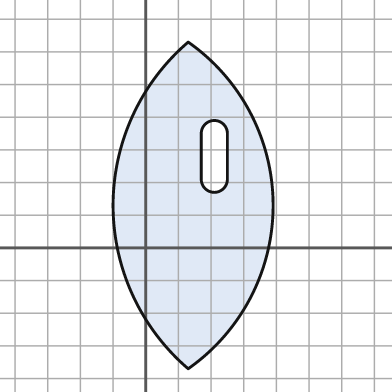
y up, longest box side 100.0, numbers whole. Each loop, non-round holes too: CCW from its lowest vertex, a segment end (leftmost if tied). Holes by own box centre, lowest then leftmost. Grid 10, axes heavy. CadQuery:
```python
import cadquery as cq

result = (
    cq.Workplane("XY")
    .moveTo(13.0, -37.0)
    .threePointArc((39.0, 13.0), (13.0, 63.0))
    .threePointArc((-10.0, 13.0), (13.0, -37.0))
    .close()
    .moveTo(17.0, 21.0)
    .threePointArc((21.0, 17.0), (25.0, 21.0))
    .lineTo(25.0, 35.0)
    .threePointArc((21.0, 39.0), (17.0, 35.0))
    .close()
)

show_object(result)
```